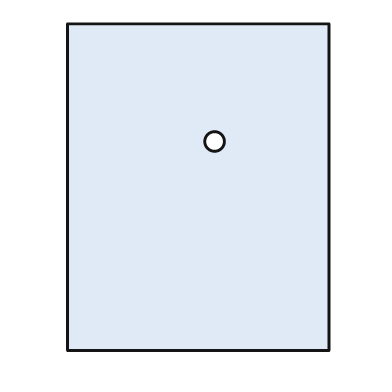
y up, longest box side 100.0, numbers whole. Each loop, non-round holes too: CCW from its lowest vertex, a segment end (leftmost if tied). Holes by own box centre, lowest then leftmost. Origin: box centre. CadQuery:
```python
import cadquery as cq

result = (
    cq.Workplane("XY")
    .moveTo(-40.0, -50.0)
    .lineTo(40.0, -50.0)
    .lineTo(40.0, 50.0)
    .lineTo(-40.0, 50.0)
    .close()
    .moveTo(5.0, 14.0)
    .circle(3.0)
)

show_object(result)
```